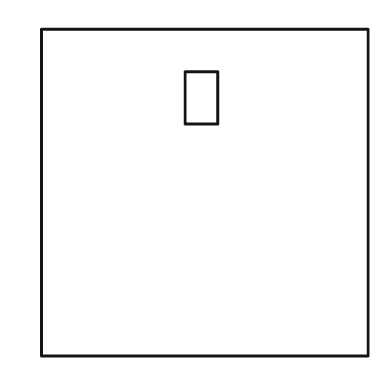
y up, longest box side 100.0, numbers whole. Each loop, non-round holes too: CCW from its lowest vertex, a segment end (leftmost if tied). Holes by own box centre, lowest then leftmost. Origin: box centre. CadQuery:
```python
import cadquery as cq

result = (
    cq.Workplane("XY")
    .moveTo(-50.0, -50.0)
    .lineTo(50.0, -50.0)
    .lineTo(50.0, 50.0)
    .lineTo(-50.0, 50.0)
    .close()
    .moveTo(-6.0, 21.0)
    .lineTo(4.0, 21.0)
    .lineTo(4.0, 37.0)
    .lineTo(-6.0, 37.0)
    .close()
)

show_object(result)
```